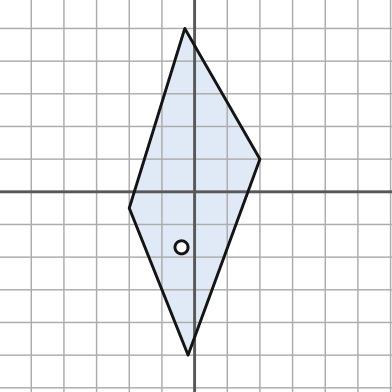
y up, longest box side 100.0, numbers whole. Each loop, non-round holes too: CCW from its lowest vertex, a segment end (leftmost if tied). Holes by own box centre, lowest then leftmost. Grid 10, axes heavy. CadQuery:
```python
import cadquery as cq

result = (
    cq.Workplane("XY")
    .moveTo(-2.0, -50.0)
    .lineTo(20.0, 10.0)
    .lineTo(-3.0, 50.0)
    .lineTo(-20.0, -5.0)
    .close()
    .moveTo(-4.0, -17.0)
    .circle(2.0)
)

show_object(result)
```